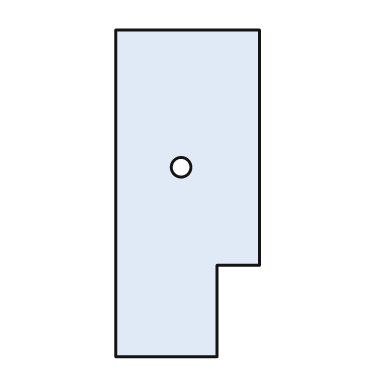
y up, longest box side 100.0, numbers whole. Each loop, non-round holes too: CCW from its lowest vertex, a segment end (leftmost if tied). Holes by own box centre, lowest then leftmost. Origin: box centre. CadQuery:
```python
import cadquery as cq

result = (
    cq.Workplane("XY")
    .moveTo(-22.0, -50.0)
    .lineTo(9.0, -50.0)
    .lineTo(9.0, -22.0)
    .lineTo(22.0, -22.0)
    .lineTo(22.0, 50.0)
    .lineTo(-22.0, 50.0)
    .close()
    .moveTo(-2.0, 8.0)
    .circle(3.0)
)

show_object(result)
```